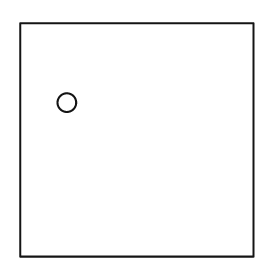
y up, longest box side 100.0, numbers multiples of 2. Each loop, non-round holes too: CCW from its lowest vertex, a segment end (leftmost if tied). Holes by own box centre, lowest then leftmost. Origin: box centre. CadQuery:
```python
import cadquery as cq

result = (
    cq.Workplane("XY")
    .moveTo(-50.0, -50.0)
    .lineTo(50.0, -50.0)
    .lineTo(50.0, 50.0)
    .lineTo(-50.0, 50.0)
    .close()
    .moveTo(-30.0, 16.0)
    .circle(4.0)
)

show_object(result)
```